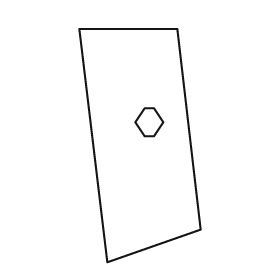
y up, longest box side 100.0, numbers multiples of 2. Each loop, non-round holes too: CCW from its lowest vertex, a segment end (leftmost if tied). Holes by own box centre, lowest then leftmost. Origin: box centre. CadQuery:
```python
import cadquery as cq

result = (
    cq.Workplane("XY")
    .moveTo(-14.0, -50.0)
    .lineTo(26.0, -36.0)
    .lineTo(16.0, 50.0)
    .lineTo(-26.0, 50.0)
    .close()
    .moveTo(2.0, 4.0)
    .lineTo(6.0, 4.0)
    .lineTo(10.0, 10.0)
    .lineTo(6.0, 16.0)
    .lineTo(2.0, 16.0)
    .lineTo(-2.0, 10.0)
    .close()
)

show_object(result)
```